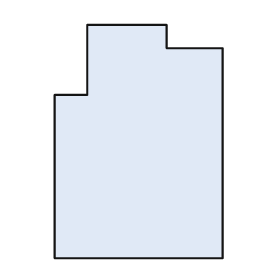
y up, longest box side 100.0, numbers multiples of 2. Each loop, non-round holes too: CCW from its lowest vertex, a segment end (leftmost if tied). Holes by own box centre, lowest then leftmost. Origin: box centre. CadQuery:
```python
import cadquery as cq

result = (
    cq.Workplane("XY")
    .moveTo(-36.0, -50.0)
    .lineTo(36.0, -50.0)
    .lineTo(36.0, 40.0)
    .lineTo(12.0, 40.0)
    .lineTo(12.0, 50.0)
    .lineTo(-22.0, 50.0)
    .lineTo(-22.0, 20.0)
    .lineTo(-36.0, 20.0)
    .close()
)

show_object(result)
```